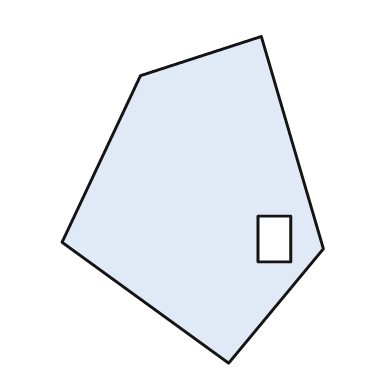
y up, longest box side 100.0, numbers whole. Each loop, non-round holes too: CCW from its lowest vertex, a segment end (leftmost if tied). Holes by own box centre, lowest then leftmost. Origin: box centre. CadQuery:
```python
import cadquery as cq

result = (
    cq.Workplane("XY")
    .moveTo(11.0, -50.0)
    .lineTo(40.0, -15.0)
    .lineTo(21.0, 50.0)
    .lineTo(-16.0, 38.0)
    .lineTo(-40.0, -13.0)
    .close()
    .moveTo(20.0, -19.0)
    .lineTo(30.0, -19.0)
    .lineTo(30.0, -5.0)
    .lineTo(20.0, -5.0)
    .close()
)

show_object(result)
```